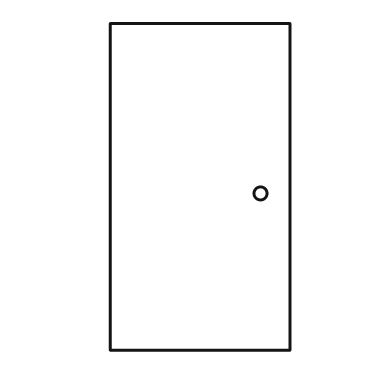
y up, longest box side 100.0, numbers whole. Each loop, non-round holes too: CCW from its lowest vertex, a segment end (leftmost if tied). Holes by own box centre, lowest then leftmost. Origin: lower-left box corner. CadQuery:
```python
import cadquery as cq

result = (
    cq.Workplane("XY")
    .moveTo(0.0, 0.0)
    .lineTo(55.0, 0.0)
    .lineTo(55.0, 100.0)
    .lineTo(0.0, 100.0)
    .close()
    .moveTo(46.0, 48.0)
    .circle(2.0)
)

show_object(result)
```